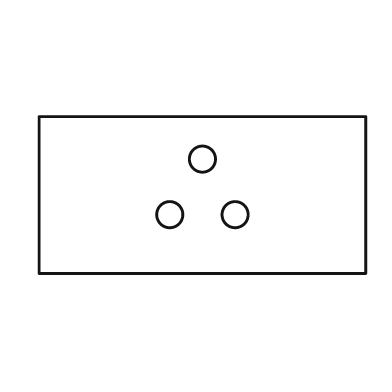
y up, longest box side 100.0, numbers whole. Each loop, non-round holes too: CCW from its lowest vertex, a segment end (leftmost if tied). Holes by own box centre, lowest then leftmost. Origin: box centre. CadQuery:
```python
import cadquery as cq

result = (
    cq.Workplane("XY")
    .moveTo(-50.0, -24.0)
    .lineTo(50.0, -24.0)
    .lineTo(50.0, 24.0)
    .lineTo(-50.0, 24.0)
    .close()
    .moveTo(-10.0, -6.0)
    .circle(4.0)
    .moveTo(10.0, -6.0)
    .circle(4.0)
    .moveTo(0.0, 11.0)
    .circle(4.0)
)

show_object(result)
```